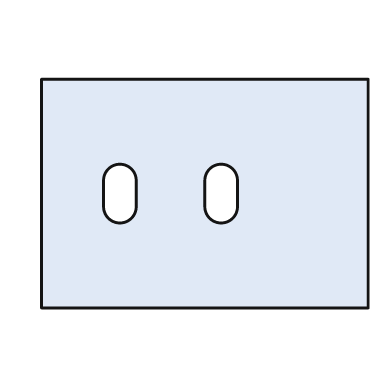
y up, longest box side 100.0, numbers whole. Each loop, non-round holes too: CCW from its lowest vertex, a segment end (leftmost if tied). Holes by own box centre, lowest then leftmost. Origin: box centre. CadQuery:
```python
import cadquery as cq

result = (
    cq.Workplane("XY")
    .moveTo(-50.0, -35.0)
    .lineTo(50.0, -35.0)
    .lineTo(50.0, 35.0)
    .lineTo(-50.0, 35.0)
    .close()
    .moveTo(-31.0, -4.0)
    .threePointArc((-26.0, -9.0), (-21.0, -4.0))
    .lineTo(-21.0, 4.0)
    .threePointArc((-26.0, 9.0), (-31.0, 4.0))
    .close()
    .moveTo(0.0, -4.0)
    .threePointArc((5.0, -9.0), (10.0, -4.0))
    .lineTo(10.0, 4.0)
    .threePointArc((5.0, 9.0), (0.0, 4.0))
    .close()
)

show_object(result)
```